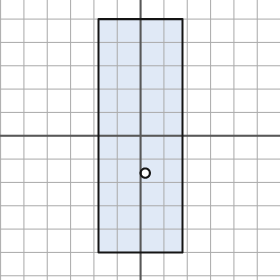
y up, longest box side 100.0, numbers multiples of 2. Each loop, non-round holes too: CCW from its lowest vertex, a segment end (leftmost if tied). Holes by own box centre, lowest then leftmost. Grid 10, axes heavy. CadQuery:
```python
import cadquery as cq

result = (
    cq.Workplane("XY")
    .moveTo(-18.0, -50.0)
    .lineTo(18.0, -50.0)
    .lineTo(18.0, 50.0)
    .lineTo(-18.0, 50.0)
    .close()
    .moveTo(2.0, -16.0)
    .circle(2.0)
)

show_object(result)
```